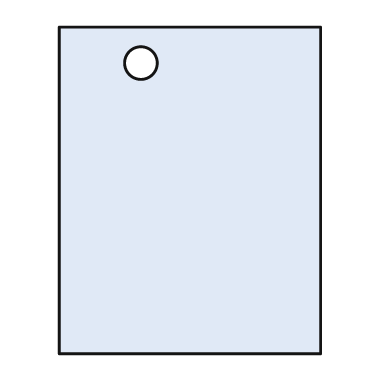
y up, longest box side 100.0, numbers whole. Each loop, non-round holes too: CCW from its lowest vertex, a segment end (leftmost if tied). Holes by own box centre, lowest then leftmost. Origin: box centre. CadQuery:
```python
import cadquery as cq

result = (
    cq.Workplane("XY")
    .moveTo(-40.0, -50.0)
    .lineTo(40.0, -50.0)
    .lineTo(40.0, 50.0)
    .lineTo(-40.0, 50.0)
    .close()
    .moveTo(-15.0, 39.0)
    .circle(5.0)
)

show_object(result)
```